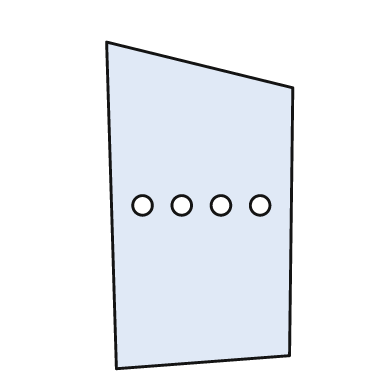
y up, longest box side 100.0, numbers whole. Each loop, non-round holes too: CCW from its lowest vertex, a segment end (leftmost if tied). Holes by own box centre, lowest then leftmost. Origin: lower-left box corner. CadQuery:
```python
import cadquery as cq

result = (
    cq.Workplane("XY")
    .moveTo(3.0, 0.0)
    .lineTo(56.0, 4.0)
    .lineTo(57.0, 86.0)
    .lineTo(0.0, 100.0)
    .close()
    .moveTo(11.0, 50.0)
    .circle(3.0)
    .moveTo(23.0, 50.0)
    .circle(3.0)
    .moveTo(35.0, 50.0)
    .circle(3.0)
    .moveTo(47.0, 50.0)
    .circle(3.0)
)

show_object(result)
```